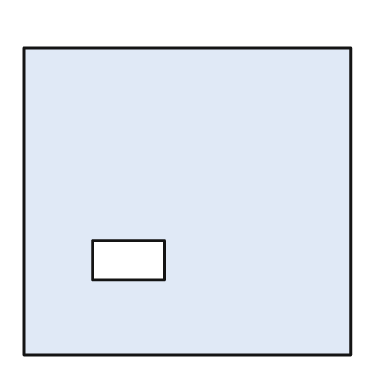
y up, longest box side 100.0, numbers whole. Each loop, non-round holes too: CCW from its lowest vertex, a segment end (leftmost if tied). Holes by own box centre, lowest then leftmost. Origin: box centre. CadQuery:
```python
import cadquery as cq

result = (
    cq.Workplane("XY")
    .moveTo(-50.0, -47.0)
    .lineTo(50.0, -47.0)
    .lineTo(50.0, 47.0)
    .lineTo(-50.0, 47.0)
    .close()
    .moveTo(-29.0, -24.0)
    .lineTo(-7.0, -24.0)
    .lineTo(-7.0, -12.0)
    .lineTo(-29.0, -12.0)
    .close()
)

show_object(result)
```